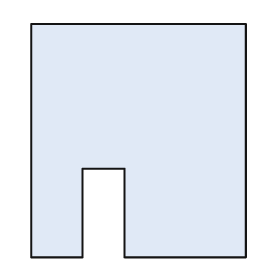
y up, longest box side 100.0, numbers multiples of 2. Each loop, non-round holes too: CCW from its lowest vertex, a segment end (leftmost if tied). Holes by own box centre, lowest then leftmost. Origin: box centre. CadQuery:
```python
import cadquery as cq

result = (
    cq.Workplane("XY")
    .moveTo(-46.0, -50.0)
    .lineTo(-24.0, -50.0)
    .lineTo(-24.0, -12.0)
    .lineTo(-6.0, -12.0)
    .lineTo(-6.0, -50.0)
    .lineTo(46.0, -50.0)
    .lineTo(46.0, 50.0)
    .lineTo(-46.0, 50.0)
    .close()
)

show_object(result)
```